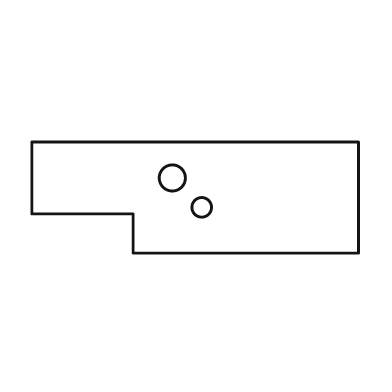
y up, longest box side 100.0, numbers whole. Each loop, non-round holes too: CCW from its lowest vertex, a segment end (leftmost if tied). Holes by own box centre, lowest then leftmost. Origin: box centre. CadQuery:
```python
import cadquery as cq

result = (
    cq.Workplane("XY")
    .moveTo(-19.0, -17.0)
    .lineTo(50.0, -17.0)
    .lineTo(50.0, 17.0)
    .lineTo(-50.0, 17.0)
    .lineTo(-50.0, -5.0)
    .lineTo(-19.0, -5.0)
    .close()
    .moveTo(2.0, -3.0)
    .circle(3.0)
    .moveTo(-7.0, 6.0)
    .circle(4.0)
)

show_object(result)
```